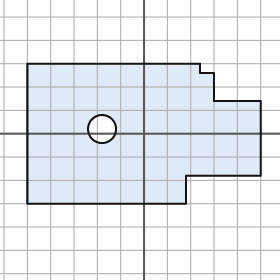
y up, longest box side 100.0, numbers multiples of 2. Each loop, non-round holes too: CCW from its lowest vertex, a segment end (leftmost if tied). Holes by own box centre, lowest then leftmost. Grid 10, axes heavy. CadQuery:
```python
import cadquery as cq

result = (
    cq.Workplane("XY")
    .moveTo(-50.0, -30.0)
    .lineTo(18.0, -30.0)
    .lineTo(18.0, -18.0)
    .lineTo(50.0, -18.0)
    .lineTo(50.0, 14.0)
    .lineTo(30.0, 14.0)
    .lineTo(30.0, 26.0)
    .lineTo(24.0, 26.0)
    .lineTo(24.0, 30.0)
    .lineTo(-50.0, 30.0)
    .close()
    .moveTo(-18.0, 2.0)
    .circle(6.0)
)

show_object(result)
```